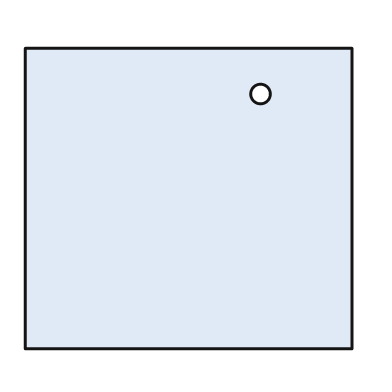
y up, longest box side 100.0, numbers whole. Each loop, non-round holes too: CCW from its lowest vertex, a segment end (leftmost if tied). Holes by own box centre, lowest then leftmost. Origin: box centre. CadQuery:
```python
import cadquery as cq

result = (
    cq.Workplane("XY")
    .moveTo(-50.0, -46.0)
    .lineTo(50.0, -46.0)
    .lineTo(50.0, 46.0)
    .lineTo(-50.0, 46.0)
    .close()
    .moveTo(22.0, 32.0)
    .circle(3.0)
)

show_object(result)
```